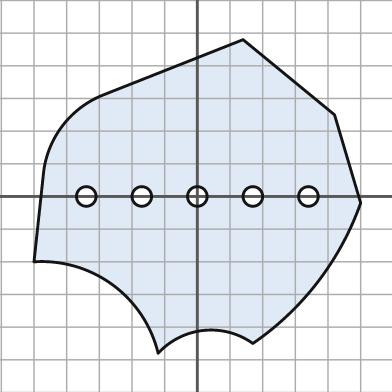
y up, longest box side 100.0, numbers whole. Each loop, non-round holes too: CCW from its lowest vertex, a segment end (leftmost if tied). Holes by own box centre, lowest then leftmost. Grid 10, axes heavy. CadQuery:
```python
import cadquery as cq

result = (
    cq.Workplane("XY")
    .moveTo(-12.0, -48.0)
    .threePointArc((2.0, -41.0), (17.0, -45.0))
    .threePointArc((37.0, -26.0), (50.0, -2.0))
    .lineTo(42.0, 25.0)
    .lineTo(14.0, 48.0)
    .lineTo(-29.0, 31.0)
    .threePointArc((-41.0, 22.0), (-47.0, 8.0))
    .lineTo(-50.0, -20.0)
    .threePointArc((-26.0, -27.0), (-12.0, -48.0))
    .close()
    .moveTo(-34.0, 0.0)
    .circle(3.0)
    .moveTo(-17.0, 0.0)
    .circle(3.0)
    .moveTo(0.0, 0.0)
    .circle(3.0)
    .moveTo(17.0, 0.0)
    .circle(3.0)
    .moveTo(34.0, 0.0)
    .circle(3.0)
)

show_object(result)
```